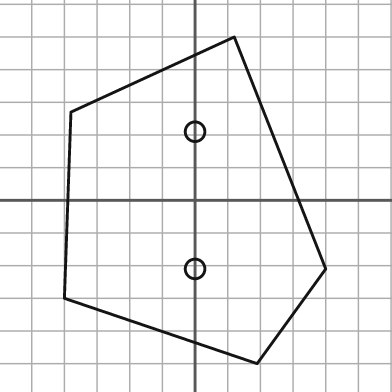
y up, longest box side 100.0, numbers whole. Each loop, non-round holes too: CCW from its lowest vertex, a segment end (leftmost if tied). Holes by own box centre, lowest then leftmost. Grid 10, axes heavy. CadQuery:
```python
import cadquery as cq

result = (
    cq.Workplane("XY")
    .moveTo(19.0, -50.0)
    .lineTo(40.0, -21.0)
    .lineTo(12.0, 50.0)
    .lineTo(-38.0, 27.0)
    .lineTo(-40.0, -30.0)
    .close()
    .moveTo(0.0, -21.0)
    .circle(3.0)
    .moveTo(0.0, 21.0)
    .circle(3.0)
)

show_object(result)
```